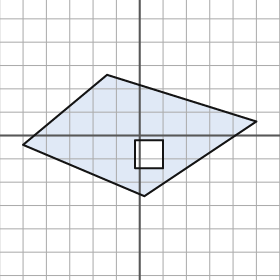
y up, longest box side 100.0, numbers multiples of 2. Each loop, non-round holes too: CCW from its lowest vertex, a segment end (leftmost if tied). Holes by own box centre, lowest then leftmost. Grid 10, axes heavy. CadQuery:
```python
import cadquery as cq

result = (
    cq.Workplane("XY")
    .moveTo(2.0, -26.0)
    .lineTo(50.0, 6.0)
    .lineTo(-14.0, 26.0)
    .lineTo(-50.0, -4.0)
    .close()
    .moveTo(-2.0, -14.0)
    .lineTo(10.0, -14.0)
    .lineTo(10.0, -2.0)
    .lineTo(-2.0, -2.0)
    .close()
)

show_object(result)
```